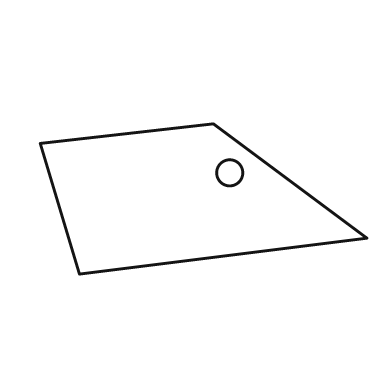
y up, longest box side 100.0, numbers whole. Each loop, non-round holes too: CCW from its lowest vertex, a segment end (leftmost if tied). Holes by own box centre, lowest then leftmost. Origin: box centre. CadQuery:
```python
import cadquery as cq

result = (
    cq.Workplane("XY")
    .moveTo(-38.0, -23.0)
    .lineTo(50.0, -12.0)
    .lineTo(3.0, 23.0)
    .lineTo(-50.0, 17.0)
    .close()
    .moveTo(8.0, 8.0)
    .circle(4.0)
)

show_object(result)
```